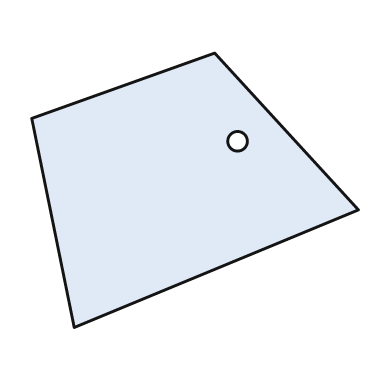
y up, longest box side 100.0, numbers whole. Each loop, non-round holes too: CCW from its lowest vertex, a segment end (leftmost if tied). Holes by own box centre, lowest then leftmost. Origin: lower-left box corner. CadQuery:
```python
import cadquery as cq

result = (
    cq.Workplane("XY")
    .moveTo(13.0, 0.0)
    .lineTo(100.0, 36.0)
    .lineTo(56.0, 84.0)
    .lineTo(0.0, 64.0)
    .close()
    .moveTo(63.0, 57.0)
    .circle(3.0)
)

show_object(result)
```